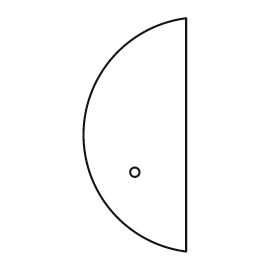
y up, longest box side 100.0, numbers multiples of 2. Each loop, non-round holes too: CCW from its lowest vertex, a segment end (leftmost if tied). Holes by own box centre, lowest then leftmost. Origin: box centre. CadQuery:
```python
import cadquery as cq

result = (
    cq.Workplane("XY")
    .moveTo(22.0, -50.0)
    .lineTo(22.0, 50.0)
    .threePointArc((-22.0, 0.0), (22.0, -50.0))
    .close()
    .moveTo(0.0, -16.0)
    .circle(2.0)
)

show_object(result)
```